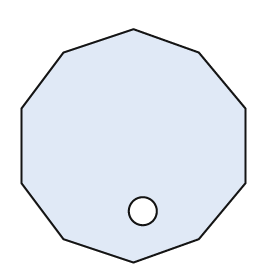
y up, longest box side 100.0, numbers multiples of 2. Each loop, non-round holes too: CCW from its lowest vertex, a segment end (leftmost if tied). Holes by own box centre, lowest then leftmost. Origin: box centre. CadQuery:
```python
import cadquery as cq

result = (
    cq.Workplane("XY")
    .moveTo(0.0, -50.0)
    .lineTo(28.0, -40.0)
    .lineTo(48.0, -16.0)
    .lineTo(48.0, 16.0)
    .lineTo(28.0, 40.0)
    .lineTo(0.0, 50.0)
    .lineTo(-30.0, 40.0)
    .lineTo(-48.0, 16.0)
    .lineTo(-48.0, -16.0)
    .lineTo(-30.0, -40.0)
    .close()
    .moveTo(4.0, -28.0)
    .circle(6.0)
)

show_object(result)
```